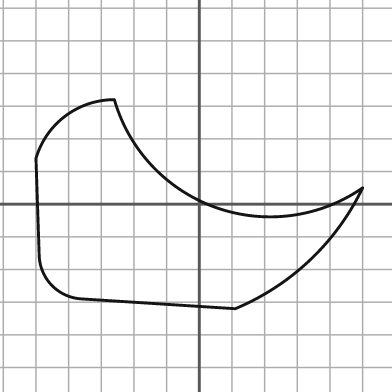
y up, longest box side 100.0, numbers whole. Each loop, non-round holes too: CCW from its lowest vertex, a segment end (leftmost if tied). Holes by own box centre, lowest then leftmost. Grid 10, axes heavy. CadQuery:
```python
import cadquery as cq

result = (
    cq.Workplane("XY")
    .moveTo(11.0, -32.0)
    .threePointArc((34.0, -17.0), (50.0, 5.0))
    .threePointArc((5.0, -1.0), (-26.0, 32.0))
    .threePointArc((-41.0, 27.0), (-50.0, 14.0))
    .lineTo(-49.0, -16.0)
    .threePointArc((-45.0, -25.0), (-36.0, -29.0))
    .close()
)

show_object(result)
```